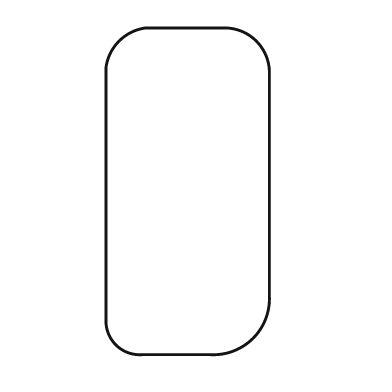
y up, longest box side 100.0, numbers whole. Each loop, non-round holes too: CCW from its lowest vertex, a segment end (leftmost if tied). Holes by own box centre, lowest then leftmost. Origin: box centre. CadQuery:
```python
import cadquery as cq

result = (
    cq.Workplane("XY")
    .moveTo(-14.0, -50.0)
    .lineTo(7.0, -50.0)
    .threePointArc((20.0, -45.0), (25.0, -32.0))
    .lineTo(25.0, 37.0)
    .threePointArc((21.0, 46.0), (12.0, 50.0))
    .lineTo(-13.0, 50.0)
    .threePointArc((-21.0, 46.0), (-25.0, 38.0))
    .lineTo(-25.0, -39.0)
    .threePointArc((-22.0, -47.0), (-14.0, -50.0))
    .close()
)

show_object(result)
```